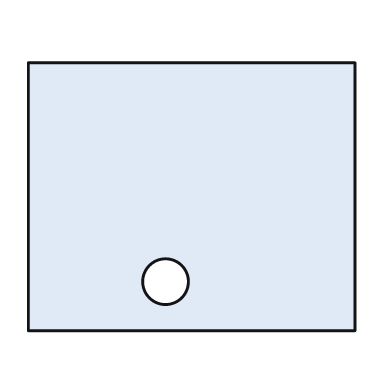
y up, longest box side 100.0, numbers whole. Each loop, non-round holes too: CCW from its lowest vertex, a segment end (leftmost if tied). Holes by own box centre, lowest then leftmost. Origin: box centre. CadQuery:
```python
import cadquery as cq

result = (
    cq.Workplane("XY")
    .moveTo(-50.0, -41.0)
    .lineTo(50.0, -41.0)
    .lineTo(50.0, 41.0)
    .lineTo(-50.0, 41.0)
    .close()
    .moveTo(-8.0, -26.0)
    .circle(7.0)
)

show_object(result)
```